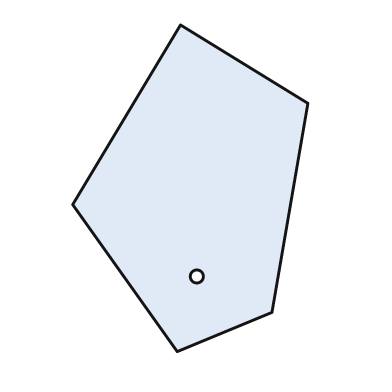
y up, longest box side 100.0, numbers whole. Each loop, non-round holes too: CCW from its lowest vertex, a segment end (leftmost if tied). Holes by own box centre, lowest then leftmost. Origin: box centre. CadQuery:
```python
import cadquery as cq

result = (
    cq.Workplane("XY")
    .moveTo(-4.0, -50.0)
    .lineTo(25.0, -38.0)
    .lineTo(36.0, 26.0)
    .lineTo(-3.0, 50.0)
    .lineTo(-36.0, -5.0)
    .close()
    .moveTo(2.0, -27.0)
    .circle(2.0)
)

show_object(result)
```